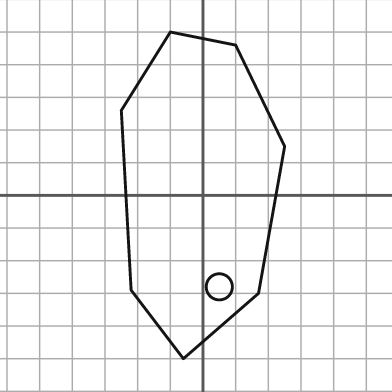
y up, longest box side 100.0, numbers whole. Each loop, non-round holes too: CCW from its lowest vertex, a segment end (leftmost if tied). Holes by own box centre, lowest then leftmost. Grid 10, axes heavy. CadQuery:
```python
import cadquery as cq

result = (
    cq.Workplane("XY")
    .moveTo(-6.0, -50.0)
    .lineTo(17.0, -30.0)
    .lineTo(25.0, 15.0)
    .lineTo(10.0, 46.0)
    .lineTo(-10.0, 50.0)
    .lineTo(-25.0, 26.0)
    .lineTo(-22.0, -29.0)
    .close()
    .moveTo(5.0, -28.0)
    .circle(4.0)
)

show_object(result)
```